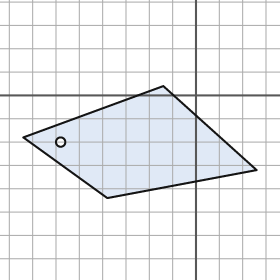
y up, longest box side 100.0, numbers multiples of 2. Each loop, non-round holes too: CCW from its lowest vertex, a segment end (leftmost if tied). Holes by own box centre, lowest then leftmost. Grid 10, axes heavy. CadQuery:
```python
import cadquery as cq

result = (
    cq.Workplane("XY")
    .moveTo(-38.0, -44.0)
    .lineTo(26.0, -32.0)
    .lineTo(-14.0, 4.0)
    .lineTo(-74.0, -18.0)
    .close()
    .moveTo(-58.0, -20.0)
    .circle(2.0)
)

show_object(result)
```